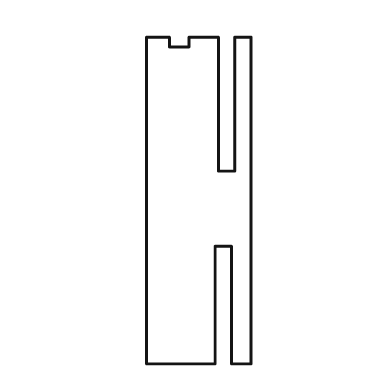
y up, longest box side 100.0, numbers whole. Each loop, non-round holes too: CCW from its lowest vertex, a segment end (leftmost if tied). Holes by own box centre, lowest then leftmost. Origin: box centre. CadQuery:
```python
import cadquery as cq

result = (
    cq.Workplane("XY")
    .moveTo(-16.0, -50.0)
    .lineTo(5.0, -50.0)
    .lineTo(5.0, -14.0)
    .lineTo(10.0, -14.0)
    .lineTo(10.0, -50.0)
    .lineTo(16.0, -50.0)
    .lineTo(16.0, 50.0)
    .lineTo(11.0, 50.0)
    .lineTo(11.0, 9.0)
    .lineTo(6.0, 9.0)
    .lineTo(6.0, 50.0)
    .lineTo(-3.0, 50.0)
    .lineTo(-3.0, 47.0)
    .lineTo(-9.0, 47.0)
    .lineTo(-9.0, 50.0)
    .lineTo(-16.0, 50.0)
    .close()
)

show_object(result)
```